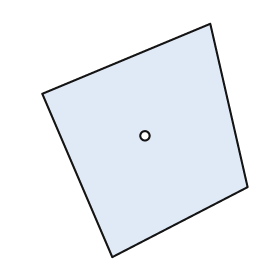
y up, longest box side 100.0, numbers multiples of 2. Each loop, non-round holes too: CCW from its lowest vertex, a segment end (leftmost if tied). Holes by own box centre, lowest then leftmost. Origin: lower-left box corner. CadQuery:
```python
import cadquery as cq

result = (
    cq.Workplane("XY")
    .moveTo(30.0, 0.0)
    .lineTo(88.0, 30.0)
    .lineTo(72.0, 100.0)
    .lineTo(0.0, 70.0)
    .close()
    .moveTo(44.0, 52.0)
    .circle(2.0)
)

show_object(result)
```